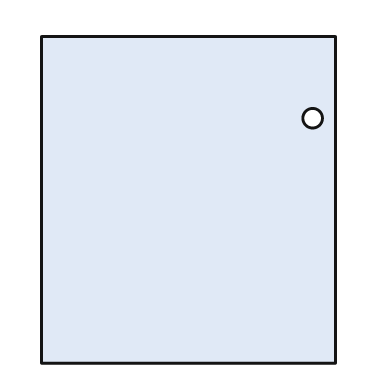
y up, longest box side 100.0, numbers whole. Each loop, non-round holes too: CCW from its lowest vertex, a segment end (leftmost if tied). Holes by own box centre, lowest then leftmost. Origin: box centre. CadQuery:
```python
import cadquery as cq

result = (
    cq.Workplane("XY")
    .moveTo(-45.0, -50.0)
    .lineTo(45.0, -50.0)
    .lineTo(45.0, 50.0)
    .lineTo(-45.0, 50.0)
    .close()
    .moveTo(38.0, 25.0)
    .circle(3.0)
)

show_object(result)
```